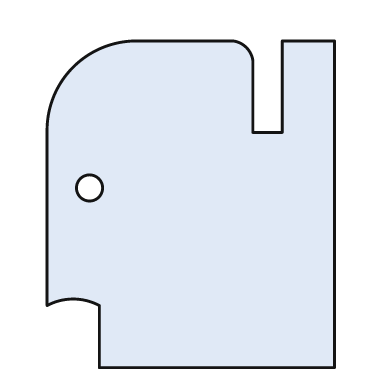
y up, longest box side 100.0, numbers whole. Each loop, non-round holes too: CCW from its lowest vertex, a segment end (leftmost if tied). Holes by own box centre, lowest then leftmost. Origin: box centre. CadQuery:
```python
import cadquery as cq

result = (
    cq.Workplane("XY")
    .moveTo(-28.0, -50.0)
    .lineTo(44.0, -50.0)
    .lineTo(44.0, 50.0)
    .lineTo(28.0, 50.0)
    .lineTo(28.0, 22.0)
    .lineTo(19.0, 22.0)
    .lineTo(19.0, 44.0)
    .threePointArc((17.0, 48.0), (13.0, 50.0))
    .lineTo(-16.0, 50.0)
    .threePointArc((-36.0, 42.0), (-44.0, 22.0))
    .lineTo(-44.0, -31.0)
    .threePointArc((-36.0, -29.0), (-28.0, -31.0))
    .close()
    .moveTo(-31.0, 5.0)
    .circle(4.0)
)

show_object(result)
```